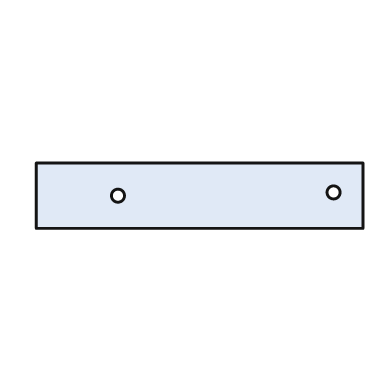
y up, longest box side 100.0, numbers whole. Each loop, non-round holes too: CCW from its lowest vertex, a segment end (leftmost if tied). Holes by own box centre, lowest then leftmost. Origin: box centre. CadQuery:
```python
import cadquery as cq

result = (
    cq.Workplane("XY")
    .moveTo(-50.0, -10.0)
    .lineTo(50.0, -10.0)
    .lineTo(50.0, 10.0)
    .lineTo(-50.0, 10.0)
    .close()
    .moveTo(-25.0, 0.0)
    .circle(2.0)
    .moveTo(41.0, 1.0)
    .circle(2.0)
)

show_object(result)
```